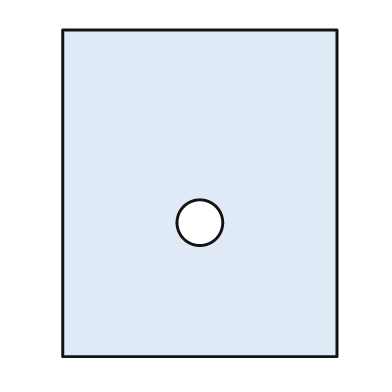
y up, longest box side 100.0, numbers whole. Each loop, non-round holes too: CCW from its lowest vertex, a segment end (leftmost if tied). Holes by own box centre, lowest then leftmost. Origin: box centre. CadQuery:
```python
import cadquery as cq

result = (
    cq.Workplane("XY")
    .moveTo(-42.0, -50.0)
    .lineTo(42.0, -50.0)
    .lineTo(42.0, 50.0)
    .lineTo(-42.0, 50.0)
    .close()
    .moveTo(0.0, -9.0)
    .circle(7.0)
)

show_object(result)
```